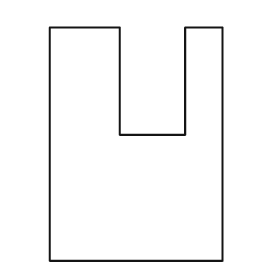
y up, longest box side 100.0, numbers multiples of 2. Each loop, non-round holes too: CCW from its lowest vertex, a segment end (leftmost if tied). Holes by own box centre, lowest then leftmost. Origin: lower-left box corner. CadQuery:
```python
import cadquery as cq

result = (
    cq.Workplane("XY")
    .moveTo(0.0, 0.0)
    .lineTo(74.0, 0.0)
    .lineTo(74.0, 100.0)
    .lineTo(58.0, 100.0)
    .lineTo(58.0, 54.0)
    .lineTo(30.0, 54.0)
    .lineTo(30.0, 100.0)
    .lineTo(0.0, 100.0)
    .close()
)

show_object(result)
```